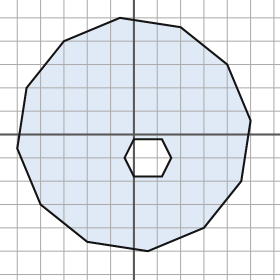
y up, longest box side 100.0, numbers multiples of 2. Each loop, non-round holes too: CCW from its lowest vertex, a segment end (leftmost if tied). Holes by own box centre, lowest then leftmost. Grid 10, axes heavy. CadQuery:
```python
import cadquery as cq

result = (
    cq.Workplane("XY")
    .moveTo(6.0, -50.0)
    .lineTo(30.0, -40.0)
    .lineTo(46.0, -20.0)
    .lineTo(50.0, 6.0)
    .lineTo(40.0, 30.0)
    .lineTo(20.0, 46.0)
    .lineTo(-6.0, 50.0)
    .lineTo(-30.0, 40.0)
    .lineTo(-46.0, 20.0)
    .lineTo(-50.0, -6.0)
    .lineTo(-40.0, -30.0)
    .lineTo(-20.0, -46.0)
    .close()
    .moveTo(0.0, -18.0)
    .lineTo(12.0, -18.0)
    .lineTo(16.0, -10.0)
    .lineTo(12.0, -2.0)
    .lineTo(0.0, -2.0)
    .lineTo(-4.0, -10.0)
    .close()
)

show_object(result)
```